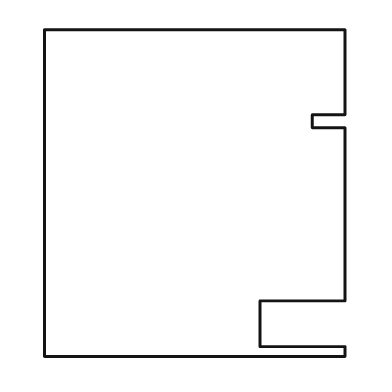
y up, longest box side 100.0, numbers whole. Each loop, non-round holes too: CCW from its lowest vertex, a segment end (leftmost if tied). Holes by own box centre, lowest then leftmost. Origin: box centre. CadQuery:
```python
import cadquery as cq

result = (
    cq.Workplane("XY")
    .moveTo(-46.0, -50.0)
    .lineTo(46.0, -50.0)
    .lineTo(46.0, -47.0)
    .lineTo(20.0, -47.0)
    .lineTo(20.0, -33.0)
    .lineTo(46.0, -33.0)
    .lineTo(46.0, 20.0)
    .lineTo(36.0, 20.0)
    .lineTo(36.0, 24.0)
    .lineTo(46.0, 24.0)
    .lineTo(46.0, 50.0)
    .lineTo(-46.0, 50.0)
    .close()
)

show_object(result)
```